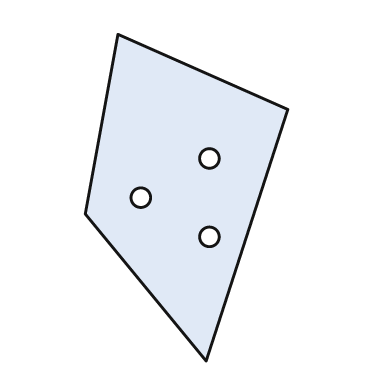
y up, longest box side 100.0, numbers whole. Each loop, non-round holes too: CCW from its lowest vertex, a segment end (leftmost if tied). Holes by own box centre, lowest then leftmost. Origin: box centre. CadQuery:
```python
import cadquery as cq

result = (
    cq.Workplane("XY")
    .moveTo(6.0, -50.0)
    .lineTo(31.0, 27.0)
    .lineTo(-21.0, 50.0)
    .lineTo(-31.0, -5.0)
    .close()
    .moveTo(7.0, -12.0)
    .circle(3.0)
    .moveTo(-14.0, 0.0)
    .circle(3.0)
    .moveTo(7.0, 12.0)
    .circle(3.0)
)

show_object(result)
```